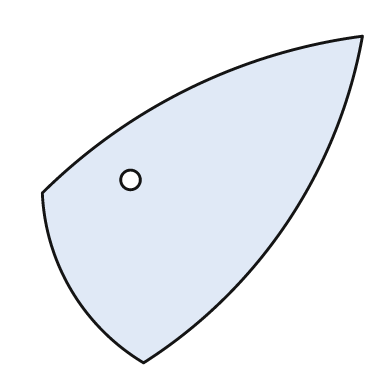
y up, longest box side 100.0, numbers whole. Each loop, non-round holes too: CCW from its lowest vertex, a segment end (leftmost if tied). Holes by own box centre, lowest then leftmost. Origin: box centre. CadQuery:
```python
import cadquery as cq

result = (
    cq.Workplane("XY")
    .moveTo(-18.0, -50.0)
    .threePointArc((26.0, -7.0), (49.0, 50.0))
    .threePointArc((-4.0, 34.0), (-49.0, 2.0))
    .threePointArc((-40.0, -28.0), (-18.0, -50.0))
    .close()
    .moveTo(-22.0, 6.0)
    .circle(3.0)
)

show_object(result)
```